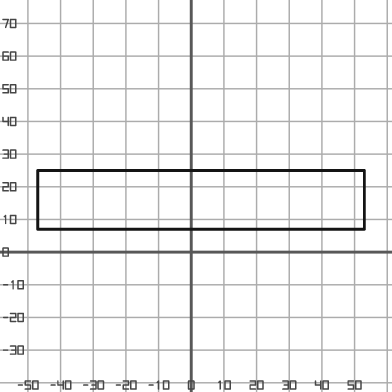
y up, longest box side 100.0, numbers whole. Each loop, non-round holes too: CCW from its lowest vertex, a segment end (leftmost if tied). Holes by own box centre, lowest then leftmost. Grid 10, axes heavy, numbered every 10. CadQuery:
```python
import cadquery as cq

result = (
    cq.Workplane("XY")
    .moveTo(-47.0, 7.0)
    .lineTo(53.0, 7.0)
    .lineTo(53.0, 25.0)
    .lineTo(-47.0, 25.0)
    .close()
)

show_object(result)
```